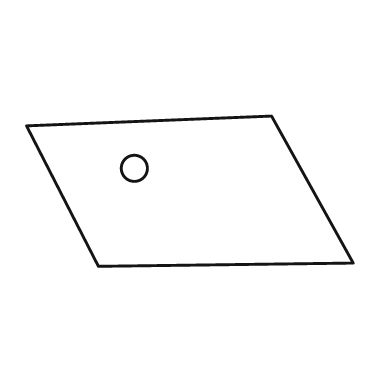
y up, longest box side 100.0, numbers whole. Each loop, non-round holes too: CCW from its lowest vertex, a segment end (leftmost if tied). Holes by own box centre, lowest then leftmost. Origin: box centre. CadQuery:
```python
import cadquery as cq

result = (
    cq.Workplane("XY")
    .moveTo(-28.0, -23.0)
    .lineTo(50.0, -22.0)
    .lineTo(25.0, 23.0)
    .lineTo(-50.0, 20.0)
    .close()
    .moveTo(-17.0, 7.0)
    .circle(4.0)
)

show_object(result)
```